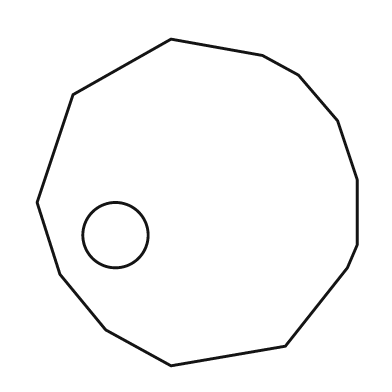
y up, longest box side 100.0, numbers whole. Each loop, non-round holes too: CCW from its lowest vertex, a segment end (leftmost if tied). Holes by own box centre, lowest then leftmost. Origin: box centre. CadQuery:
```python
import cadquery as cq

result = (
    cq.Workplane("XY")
    .moveTo(-8.0, -50.0)
    .lineTo(27.0, -44.0)
    .lineTo(46.0, -20.0)
    .lineTo(49.0, -13.0)
    .lineTo(49.0, 7.0)
    .lineTo(43.0, 25.0)
    .lineTo(31.0, 39.0)
    .lineTo(20.0, 45.0)
    .lineTo(-8.0, 50.0)
    .lineTo(-38.0, 33.0)
    .lineTo(-49.0, 0.0)
    .lineTo(-42.0, -22.0)
    .lineTo(-28.0, -39.0)
    .close()
    .moveTo(-25.0, -10.0)
    .circle(10.0)
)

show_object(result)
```